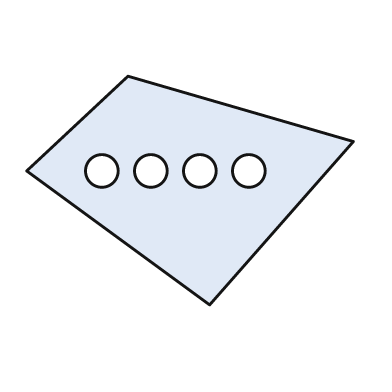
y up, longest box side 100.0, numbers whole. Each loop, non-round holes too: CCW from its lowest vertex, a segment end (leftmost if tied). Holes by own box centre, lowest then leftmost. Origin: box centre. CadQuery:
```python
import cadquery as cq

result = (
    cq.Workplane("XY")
    .moveTo(6.0, -35.0)
    .lineTo(50.0, 15.0)
    .lineTo(-19.0, 35.0)
    .lineTo(-50.0, 6.0)
    .close()
    .moveTo(-27.0, 6.0)
    .circle(5.0)
    .moveTo(-12.0, 6.0)
    .circle(5.0)
    .moveTo(3.0, 6.0)
    .circle(5.0)
    .moveTo(18.0, 6.0)
    .circle(5.0)
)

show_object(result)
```